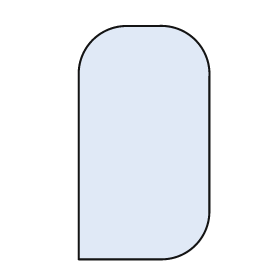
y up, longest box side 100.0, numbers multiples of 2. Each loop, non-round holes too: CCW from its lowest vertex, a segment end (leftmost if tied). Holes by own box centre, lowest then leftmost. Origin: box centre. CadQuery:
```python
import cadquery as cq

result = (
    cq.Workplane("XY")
    .moveTo(-28.0, -50.0)
    .lineTo(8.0, -50.0)
    .threePointArc((22.0, -44.0), (28.0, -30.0))
    .lineTo(28.0, 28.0)
    .threePointArc((22.0, 44.0), (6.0, 50.0))
    .lineTo(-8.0, 50.0)
    .threePointArc((-22.0, 44.0), (-28.0, 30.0))
    .close()
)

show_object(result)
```